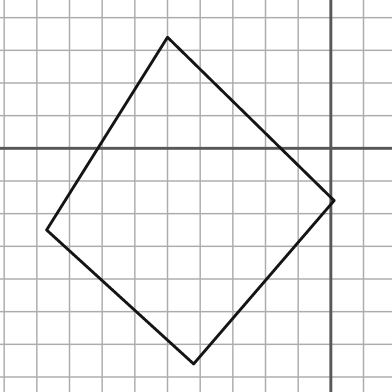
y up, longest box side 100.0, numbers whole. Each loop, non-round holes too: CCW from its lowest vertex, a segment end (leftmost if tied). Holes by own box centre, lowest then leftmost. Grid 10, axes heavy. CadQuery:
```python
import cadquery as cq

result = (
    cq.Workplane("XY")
    .moveTo(-42.0, -66.0)
    .lineTo(1.0, -16.0)
    .lineTo(-50.0, 34.0)
    .lineTo(-87.0, -25.0)
    .close()
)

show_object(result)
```